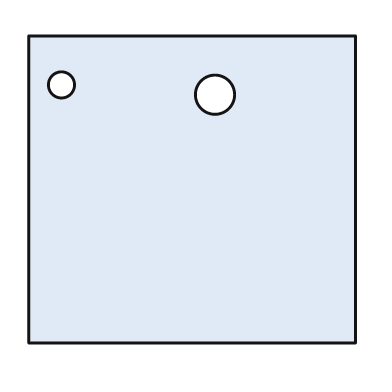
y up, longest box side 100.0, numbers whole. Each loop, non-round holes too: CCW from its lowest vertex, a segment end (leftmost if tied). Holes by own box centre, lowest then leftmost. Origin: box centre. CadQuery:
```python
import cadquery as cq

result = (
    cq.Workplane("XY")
    .moveTo(-50.0, -47.0)
    .lineTo(50.0, -47.0)
    .lineTo(50.0, 47.0)
    .lineTo(-50.0, 47.0)
    .close()
    .moveTo(7.0, 29.0)
    .circle(6.0)
    .moveTo(-40.0, 32.0)
    .circle(4.0)
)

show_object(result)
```